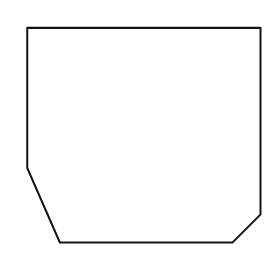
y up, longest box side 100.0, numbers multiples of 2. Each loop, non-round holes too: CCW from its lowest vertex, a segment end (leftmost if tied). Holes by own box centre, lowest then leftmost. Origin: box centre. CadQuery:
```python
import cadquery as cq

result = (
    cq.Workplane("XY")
    .moveTo(-36.0, -46.0)
    .lineTo(38.0, -46.0)
    .lineTo(50.0, -34.0)
    .lineTo(50.0, 46.0)
    .lineTo(-50.0, 46.0)
    .lineTo(-50.0, -14.0)
    .close()
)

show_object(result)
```